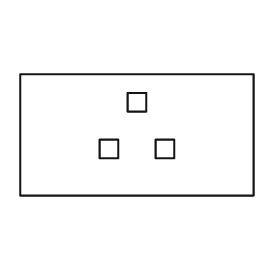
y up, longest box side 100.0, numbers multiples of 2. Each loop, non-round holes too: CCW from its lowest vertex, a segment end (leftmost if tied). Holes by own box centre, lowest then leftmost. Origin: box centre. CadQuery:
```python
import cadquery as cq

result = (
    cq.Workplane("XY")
    .moveTo(-50.0, -26.0)
    .lineTo(50.0, -26.0)
    .lineTo(50.0, 26.0)
    .lineTo(-50.0, 26.0)
    .close()
    .moveTo(-16.0, -10.0)
    .lineTo(-8.0, -10.0)
    .lineTo(-8.0, -2.0)
    .lineTo(-16.0, -2.0)
    .close()
    .moveTo(8.0, -10.0)
    .lineTo(16.0, -10.0)
    .lineTo(16.0, -2.0)
    .lineTo(8.0, -2.0)
    .close()
    .moveTo(-4.0, 10.0)
    .lineTo(4.0, 10.0)
    .lineTo(4.0, 18.0)
    .lineTo(-4.0, 18.0)
    .close()
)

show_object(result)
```